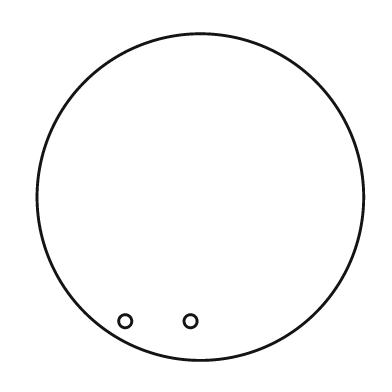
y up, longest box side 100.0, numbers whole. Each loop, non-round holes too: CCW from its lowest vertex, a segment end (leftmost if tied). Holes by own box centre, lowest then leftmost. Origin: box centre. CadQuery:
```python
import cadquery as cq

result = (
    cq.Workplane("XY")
    .moveTo(0.0, 0.0)
    .circle(50.0)
    .moveTo(-23.0, -38.0)
    .circle(2.0)
    .moveTo(-3.0, -38.0)
    .circle(2.0)
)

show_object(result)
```